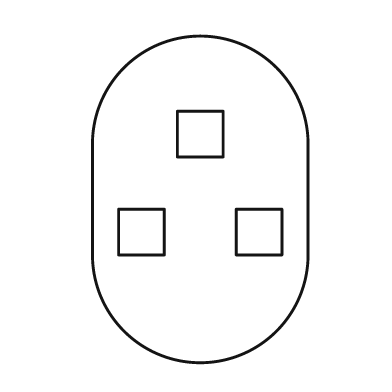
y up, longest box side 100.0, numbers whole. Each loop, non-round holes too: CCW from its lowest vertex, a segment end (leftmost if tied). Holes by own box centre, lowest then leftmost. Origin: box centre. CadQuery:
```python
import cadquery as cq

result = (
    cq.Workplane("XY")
    .moveTo(-33.0, -17.0)
    .threePointArc((0.0, -50.0), (33.0, -17.0))
    .lineTo(33.0, 17.0)
    .threePointArc((0.0, 50.0), (-33.0, 17.0))
    .close()
    .moveTo(-25.0, -17.0)
    .lineTo(-11.0, -17.0)
    .lineTo(-11.0, -3.0)
    .lineTo(-25.0, -3.0)
    .close()
    .moveTo(11.0, -17.0)
    .lineTo(25.0, -17.0)
    .lineTo(25.0, -3.0)
    .lineTo(11.0, -3.0)
    .close()
    .moveTo(-7.0, 13.0)
    .lineTo(7.0, 13.0)
    .lineTo(7.0, 27.0)
    .lineTo(-7.0, 27.0)
    .close()
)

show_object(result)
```